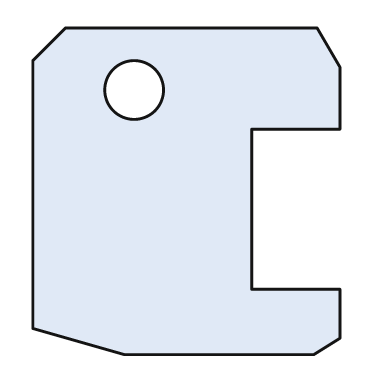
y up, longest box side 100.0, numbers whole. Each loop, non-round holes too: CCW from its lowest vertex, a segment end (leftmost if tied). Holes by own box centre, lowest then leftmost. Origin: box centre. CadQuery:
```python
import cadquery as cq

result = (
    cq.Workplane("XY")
    .moveTo(-19.0, -50.0)
    .lineTo(39.0, -50.0)
    .lineTo(47.0, -45.0)
    .lineTo(47.0, -30.0)
    .lineTo(20.0, -30.0)
    .lineTo(20.0, 19.0)
    .lineTo(47.0, 19.0)
    .lineTo(47.0, 38.0)
    .lineTo(40.0, 50.0)
    .lineTo(-37.0, 50.0)
    .lineTo(-47.0, 40.0)
    .lineTo(-47.0, -42.0)
    .close()
    .moveTo(-16.0, 31.0)
    .circle(9.0)
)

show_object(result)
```